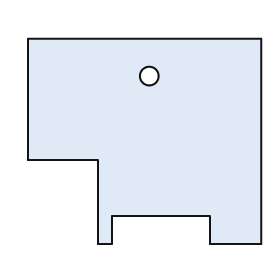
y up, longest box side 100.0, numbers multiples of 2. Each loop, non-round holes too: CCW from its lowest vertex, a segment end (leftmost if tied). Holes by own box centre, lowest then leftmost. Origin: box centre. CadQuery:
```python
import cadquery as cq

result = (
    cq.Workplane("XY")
    .moveTo(-20.0, -44.0)
    .lineTo(-14.0, -44.0)
    .lineTo(-14.0, -32.0)
    .lineTo(28.0, -32.0)
    .lineTo(28.0, -44.0)
    .lineTo(50.0, -44.0)
    .lineTo(50.0, 44.0)
    .lineTo(-50.0, 44.0)
    .lineTo(-50.0, -8.0)
    .lineTo(-20.0, -8.0)
    .close()
    .moveTo(2.0, 28.0)
    .circle(4.0)
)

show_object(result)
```